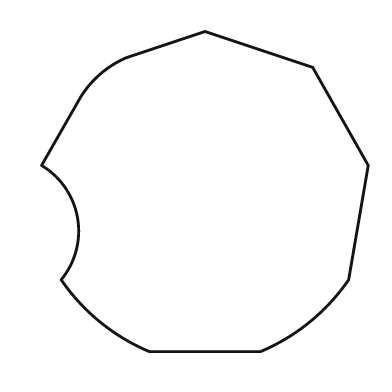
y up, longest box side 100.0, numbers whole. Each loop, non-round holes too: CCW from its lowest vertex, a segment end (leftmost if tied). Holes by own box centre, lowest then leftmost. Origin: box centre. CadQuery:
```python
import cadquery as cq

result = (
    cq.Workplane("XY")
    .moveTo(-17.0, -49.0)
    .lineTo(17.0, -49.0)
    .threePointArc((32.0, -40.0), (44.0, -27.0))
    .lineTo(50.0, 8.0)
    .lineTo(33.0, 38.0)
    .lineTo(0.0, 49.0)
    .lineTo(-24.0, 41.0)
    .threePointArc((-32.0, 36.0), (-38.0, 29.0))
    .lineTo(-50.0, 8.0)
    .threePointArc((-39.0, -8.0), (-44.0, -27.0))
    .threePointArc((-32.0, -40.0), (-17.0, -49.0))
    .close()
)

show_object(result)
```